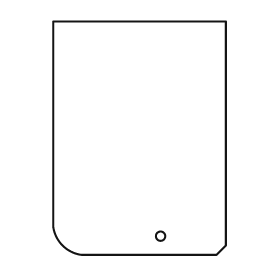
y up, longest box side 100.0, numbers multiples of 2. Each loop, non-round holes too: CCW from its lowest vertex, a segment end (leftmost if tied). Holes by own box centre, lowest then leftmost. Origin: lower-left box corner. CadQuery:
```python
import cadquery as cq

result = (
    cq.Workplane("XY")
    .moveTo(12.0, 0.0)
    .lineTo(70.0, 0.0)
    .lineTo(74.0, 4.0)
    .lineTo(74.0, 100.0)
    .lineTo(0.0, 100.0)
    .lineTo(0.0, 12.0)
    .threePointArc((4.0, 4.0), (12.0, 0.0))
    .close()
    .moveTo(46.0, 8.0)
    .circle(2.0)
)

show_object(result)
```